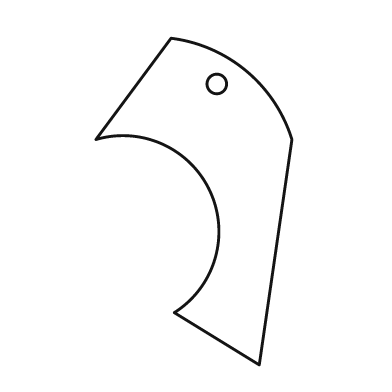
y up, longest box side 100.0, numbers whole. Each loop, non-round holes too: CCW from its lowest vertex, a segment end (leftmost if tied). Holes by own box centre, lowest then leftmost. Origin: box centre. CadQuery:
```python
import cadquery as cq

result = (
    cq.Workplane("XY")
    .moveTo(20.0, -50.0)
    .lineTo(30.0, 19.0)
    .threePointArc((16.0, 40.0), (-7.0, 50.0))
    .lineTo(-30.0, 19.0)
    .threePointArc((5.0, 3.0), (-6.0, -34.0))
    .close()
    .moveTo(7.0, 36.0)
    .circle(3.0)
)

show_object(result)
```